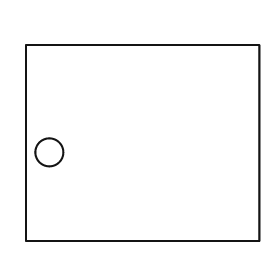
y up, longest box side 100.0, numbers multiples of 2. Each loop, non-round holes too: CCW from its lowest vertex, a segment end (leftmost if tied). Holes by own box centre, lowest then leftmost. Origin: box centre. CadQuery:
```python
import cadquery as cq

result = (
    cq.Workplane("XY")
    .moveTo(-50.0, -42.0)
    .lineTo(50.0, -42.0)
    .lineTo(50.0, 42.0)
    .lineTo(-50.0, 42.0)
    .close()
    .moveTo(-40.0, -4.0)
    .circle(6.0)
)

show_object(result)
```